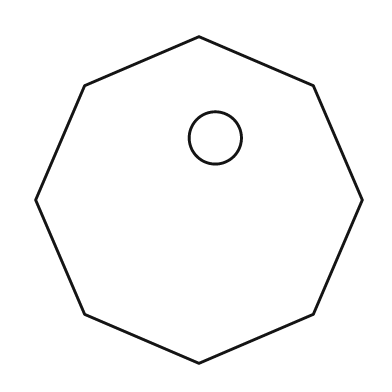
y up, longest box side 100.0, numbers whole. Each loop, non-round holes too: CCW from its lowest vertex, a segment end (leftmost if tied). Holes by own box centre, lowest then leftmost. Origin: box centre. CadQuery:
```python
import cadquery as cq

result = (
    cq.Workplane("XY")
    .moveTo(0.0, -50.0)
    .lineTo(35.0, -35.0)
    .lineTo(50.0, 0.0)
    .lineTo(35.0, 35.0)
    .lineTo(0.0, 50.0)
    .lineTo(-35.0, 35.0)
    .lineTo(-50.0, 0.0)
    .lineTo(-35.0, -35.0)
    .close()
    .moveTo(5.0, 19.0)
    .circle(8.0)
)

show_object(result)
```